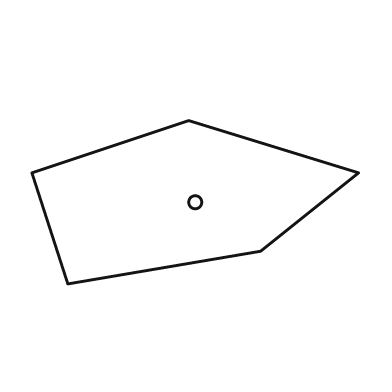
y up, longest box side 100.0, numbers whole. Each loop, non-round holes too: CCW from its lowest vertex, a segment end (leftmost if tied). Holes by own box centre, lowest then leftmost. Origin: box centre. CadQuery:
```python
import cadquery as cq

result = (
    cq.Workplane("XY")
    .moveTo(-39.0, -25.0)
    .lineTo(20.0, -15.0)
    .lineTo(50.0, 9.0)
    .lineTo(-2.0, 25.0)
    .lineTo(-50.0, 9.0)
    .close()
    .moveTo(0.0, 0.0)
    .circle(2.0)
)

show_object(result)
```